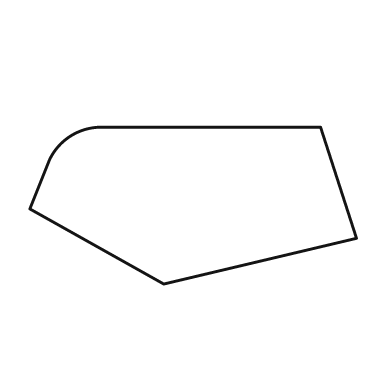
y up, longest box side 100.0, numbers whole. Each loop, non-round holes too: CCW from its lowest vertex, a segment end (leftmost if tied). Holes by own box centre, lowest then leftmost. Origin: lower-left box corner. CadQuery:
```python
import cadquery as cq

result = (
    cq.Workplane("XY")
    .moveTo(41.0, 0.0)
    .lineTo(100.0, 14.0)
    .lineTo(89.0, 48.0)
    .lineTo(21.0, 48.0)
    .threePointArc((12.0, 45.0), (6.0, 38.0))
    .lineTo(0.0, 23.0)
    .close()
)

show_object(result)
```